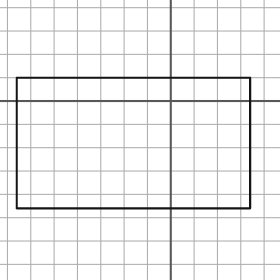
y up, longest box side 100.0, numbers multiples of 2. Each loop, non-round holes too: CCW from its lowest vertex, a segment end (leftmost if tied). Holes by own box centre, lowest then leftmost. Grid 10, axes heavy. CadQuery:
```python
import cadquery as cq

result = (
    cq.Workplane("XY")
    .moveTo(-66.0, -46.0)
    .lineTo(34.0, -46.0)
    .lineTo(34.0, 10.0)
    .lineTo(-66.0, 10.0)
    .close()
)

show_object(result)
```